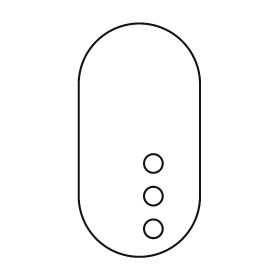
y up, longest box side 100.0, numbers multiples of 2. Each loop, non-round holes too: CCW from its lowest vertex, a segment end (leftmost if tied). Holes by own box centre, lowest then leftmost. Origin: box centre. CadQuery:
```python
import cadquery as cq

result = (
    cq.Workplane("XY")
    .moveTo(-26.0, -24.0)
    .threePointArc((0.0, -50.0), (26.0, -24.0))
    .lineTo(26.0, 24.0)
    .threePointArc((0.0, 50.0), (-26.0, 24.0))
    .close()
    .moveTo(6.0, -38.0)
    .circle(4.0)
    .moveTo(6.0, -24.0)
    .circle(4.0)
    .moveTo(6.0, -10.0)
    .circle(4.0)
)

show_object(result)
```